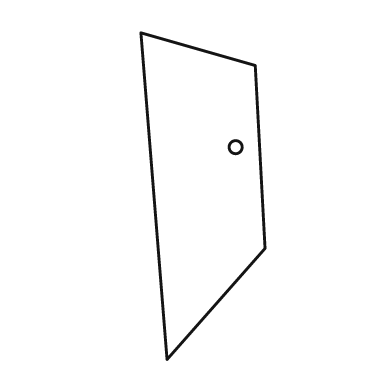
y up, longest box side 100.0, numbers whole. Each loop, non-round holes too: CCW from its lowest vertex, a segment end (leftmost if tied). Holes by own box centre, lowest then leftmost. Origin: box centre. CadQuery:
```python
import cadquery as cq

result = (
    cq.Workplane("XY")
    .moveTo(-11.0, -50.0)
    .lineTo(19.0, -16.0)
    .lineTo(16.0, 40.0)
    .lineTo(-19.0, 50.0)
    .close()
    .moveTo(10.0, 15.0)
    .circle(2.0)
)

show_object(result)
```